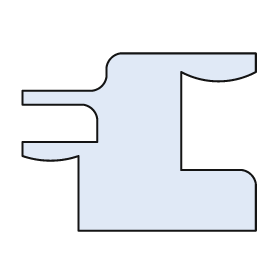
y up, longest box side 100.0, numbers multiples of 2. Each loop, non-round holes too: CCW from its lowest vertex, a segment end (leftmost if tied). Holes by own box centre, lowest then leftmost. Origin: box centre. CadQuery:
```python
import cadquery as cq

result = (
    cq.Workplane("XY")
    .moveTo(-26.0, -38.0)
    .lineTo(50.0, -38.0)
    .lineTo(50.0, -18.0)
    .threePointArc((48.0, -14.0), (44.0, -12.0))
    .lineTo(18.0, -12.0)
    .lineTo(18.0, 30.0)
    .threePointArc((34.0, 26.0), (50.0, 30.0))
    .lineTo(50.0, 38.0)
    .lineTo(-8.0, 38.0)
    .threePointArc((-12.0, 36.0), (-14.0, 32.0))
    .lineTo(-14.0, 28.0)
    .threePointArc((-16.0, 24.0), (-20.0, 22.0))
    .lineTo(-50.0, 22.0)
    .lineTo(-50.0, 16.0)
    .lineTo(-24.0, 16.0)
    .threePointArc((-20.0, 14.0), (-18.0, 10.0))
    .lineTo(-18.0, 0.0)
    .lineTo(-50.0, 0.0)
    .lineTo(-50.0, -6.0)
    .threePointArc((-38.0, -8.0), (-26.0, -6.0))
    .close()
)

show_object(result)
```